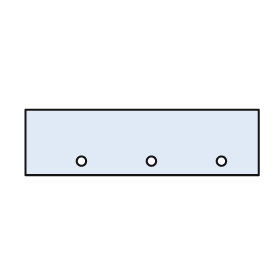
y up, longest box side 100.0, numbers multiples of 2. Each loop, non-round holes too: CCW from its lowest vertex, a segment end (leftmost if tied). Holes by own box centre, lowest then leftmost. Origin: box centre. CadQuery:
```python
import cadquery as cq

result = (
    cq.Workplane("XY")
    .moveTo(-50.0, -14.0)
    .lineTo(50.0, -14.0)
    .lineTo(50.0, 14.0)
    .lineTo(-50.0, 14.0)
    .close()
    .moveTo(-26.0, -8.0)
    .circle(2.0)
    .moveTo(4.0, -8.0)
    .circle(2.0)
    .moveTo(34.0, -8.0)
    .circle(2.0)
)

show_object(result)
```